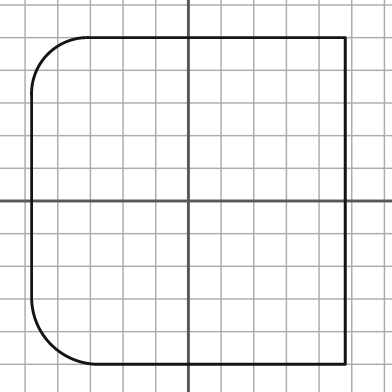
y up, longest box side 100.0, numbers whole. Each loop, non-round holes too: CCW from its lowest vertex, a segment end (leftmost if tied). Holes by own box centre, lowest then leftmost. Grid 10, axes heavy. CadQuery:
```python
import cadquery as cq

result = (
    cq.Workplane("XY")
    .moveTo(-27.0, -50.0)
    .lineTo(48.0, -50.0)
    .lineTo(48.0, 50.0)
    .lineTo(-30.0, 50.0)
    .threePointArc((-43.0, 45.0), (-48.0, 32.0))
    .lineTo(-48.0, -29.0)
    .threePointArc((-42.0, -44.0), (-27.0, -50.0))
    .close()
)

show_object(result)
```